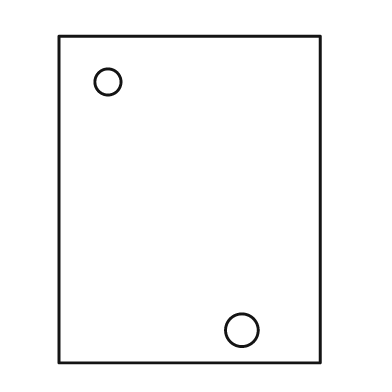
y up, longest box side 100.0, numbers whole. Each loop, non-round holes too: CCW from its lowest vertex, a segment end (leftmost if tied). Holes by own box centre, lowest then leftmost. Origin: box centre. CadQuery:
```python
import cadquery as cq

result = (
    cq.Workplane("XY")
    .moveTo(-40.0, -50.0)
    .lineTo(40.0, -50.0)
    .lineTo(40.0, 50.0)
    .lineTo(-40.0, 50.0)
    .close()
    .moveTo(16.0, -40.0)
    .circle(5.0)
    .moveTo(-25.0, 36.0)
    .circle(4.0)
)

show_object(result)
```